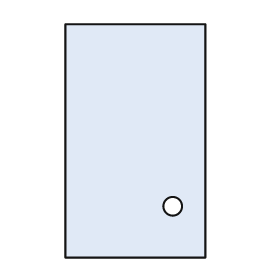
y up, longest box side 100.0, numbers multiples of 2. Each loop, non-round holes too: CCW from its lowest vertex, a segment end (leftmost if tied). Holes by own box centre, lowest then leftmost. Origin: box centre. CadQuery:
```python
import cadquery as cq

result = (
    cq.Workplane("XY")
    .moveTo(-30.0, -50.0)
    .lineTo(30.0, -50.0)
    .lineTo(30.0, 50.0)
    .lineTo(-30.0, 50.0)
    .close()
    .moveTo(16.0, -28.0)
    .circle(4.0)
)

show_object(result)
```